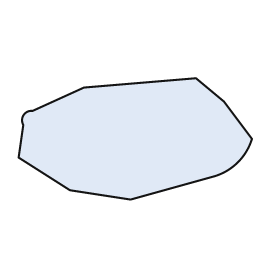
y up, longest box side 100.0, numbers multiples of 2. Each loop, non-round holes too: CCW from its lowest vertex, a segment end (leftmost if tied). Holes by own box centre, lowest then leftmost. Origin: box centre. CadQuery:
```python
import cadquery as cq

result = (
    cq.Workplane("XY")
    .moveTo(-2.0, -26.0)
    .lineTo(34.0, -16.0)
    .threePointArc((44.0, -10.0), (50.0, 0.0))
    .lineTo(38.0, 16.0)
    .lineTo(26.0, 26.0)
    .lineTo(-22.0, 22.0)
    .lineTo(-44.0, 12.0)
    .threePointArc((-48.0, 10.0), (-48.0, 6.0))
    .lineTo(-50.0, -8.0)
    .lineTo(-28.0, -22.0)
    .close()
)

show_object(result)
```